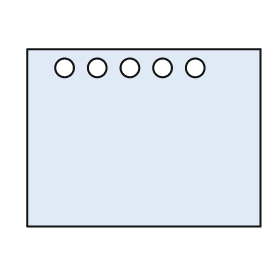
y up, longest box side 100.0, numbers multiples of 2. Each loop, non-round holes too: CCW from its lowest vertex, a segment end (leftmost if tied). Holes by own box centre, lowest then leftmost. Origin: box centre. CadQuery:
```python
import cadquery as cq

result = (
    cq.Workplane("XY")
    .moveTo(-50.0, -38.0)
    .lineTo(50.0, -38.0)
    .lineTo(50.0, 38.0)
    .lineTo(-50.0, 38.0)
    .close()
    .moveTo(-34.0, 30.0)
    .circle(4.0)
    .moveTo(-20.0, 30.0)
    .circle(4.0)
    .moveTo(-6.0, 30.0)
    .circle(4.0)
    .moveTo(8.0, 30.0)
    .circle(4.0)
    .moveTo(22.0, 30.0)
    .circle(4.0)
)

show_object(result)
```